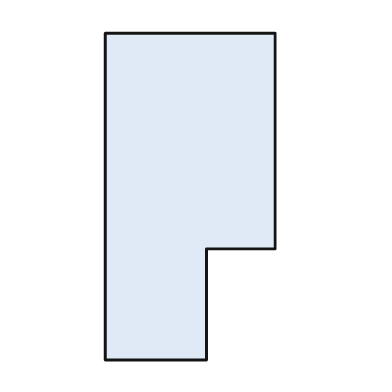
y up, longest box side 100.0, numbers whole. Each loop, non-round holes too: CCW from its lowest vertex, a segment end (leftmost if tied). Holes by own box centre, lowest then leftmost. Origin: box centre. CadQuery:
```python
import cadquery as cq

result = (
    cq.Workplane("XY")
    .moveTo(-26.0, -50.0)
    .lineTo(5.0, -50.0)
    .lineTo(5.0, -16.0)
    .lineTo(26.0, -16.0)
    .lineTo(26.0, 50.0)
    .lineTo(-26.0, 50.0)
    .close()
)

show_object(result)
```